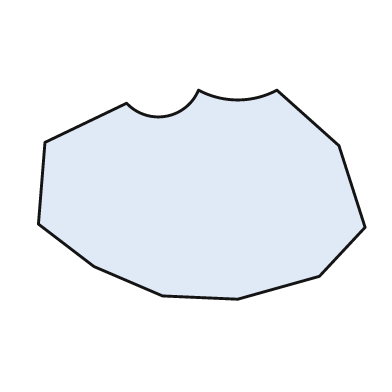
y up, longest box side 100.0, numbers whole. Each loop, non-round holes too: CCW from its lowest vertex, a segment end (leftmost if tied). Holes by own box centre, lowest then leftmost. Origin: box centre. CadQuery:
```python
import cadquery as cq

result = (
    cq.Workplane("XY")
    .moveTo(11.0, -32.0)
    .lineTo(36.0, -25.0)
    .lineTo(50.0, -10.0)
    .lineTo(42.0, 15.0)
    .lineTo(23.0, 32.0)
    .threePointArc((11.0, 29.0), (-1.0, 32.0))
    .threePointArc((-11.0, 24.0), (-23.0, 28.0))
    .lineTo(-48.0, 16.0)
    .lineTo(-50.0, -9.0)
    .lineTo(-33.0, -22.0)
    .lineTo(-12.0, -31.0)
    .close()
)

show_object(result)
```